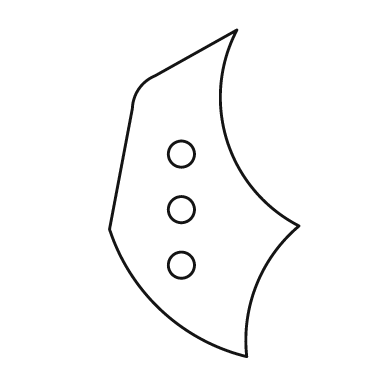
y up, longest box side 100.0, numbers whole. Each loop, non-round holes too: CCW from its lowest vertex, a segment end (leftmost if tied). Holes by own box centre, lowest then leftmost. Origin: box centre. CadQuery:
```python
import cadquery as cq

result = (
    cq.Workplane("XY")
    .moveTo(13.0, -50.0)
    .threePointArc((16.0, -28.0), (29.0, -10.0))
    .threePointArc((7.0, 16.0), (10.0, 50.0))
    .lineTo(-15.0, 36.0)
    .threePointArc((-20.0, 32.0), (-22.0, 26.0))
    .lineTo(-29.0, -11.0)
    .threePointArc((-13.0, -36.0), (13.0, -50.0))
    .close()
    .moveTo(-7.0, -22.0)
    .circle(4.0)
    .moveTo(-7.0, -5.0)
    .circle(4.0)
    .moveTo(-7.0, 12.0)
    .circle(4.0)
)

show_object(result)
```